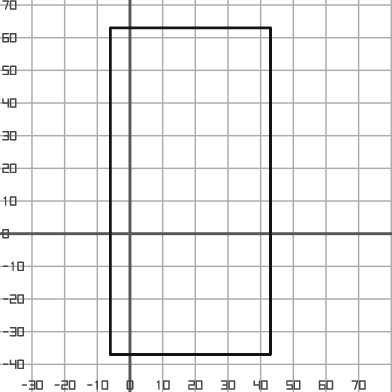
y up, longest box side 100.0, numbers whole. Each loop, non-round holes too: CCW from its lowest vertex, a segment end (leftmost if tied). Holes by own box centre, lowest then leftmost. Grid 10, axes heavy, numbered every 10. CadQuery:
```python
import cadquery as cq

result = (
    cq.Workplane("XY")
    .moveTo(-6.0, -37.0)
    .lineTo(43.0, -37.0)
    .lineTo(43.0, 63.0)
    .lineTo(-6.0, 63.0)
    .close()
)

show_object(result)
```